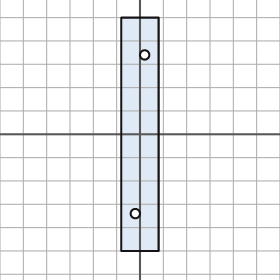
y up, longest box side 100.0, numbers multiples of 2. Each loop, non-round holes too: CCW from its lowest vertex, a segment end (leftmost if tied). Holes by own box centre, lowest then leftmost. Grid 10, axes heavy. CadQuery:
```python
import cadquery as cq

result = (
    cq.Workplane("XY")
    .moveTo(-8.0, -50.0)
    .lineTo(8.0, -50.0)
    .lineTo(8.0, 50.0)
    .lineTo(-8.0, 50.0)
    .close()
    .moveTo(-2.0, -34.0)
    .circle(2.0)
    .moveTo(2.0, 34.0)
    .circle(2.0)
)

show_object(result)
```